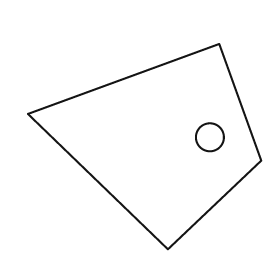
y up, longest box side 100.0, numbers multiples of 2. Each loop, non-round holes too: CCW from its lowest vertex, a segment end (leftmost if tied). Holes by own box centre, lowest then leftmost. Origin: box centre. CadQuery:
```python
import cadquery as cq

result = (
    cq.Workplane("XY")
    .moveTo(10.0, -44.0)
    .lineTo(50.0, -6.0)
    .lineTo(32.0, 44.0)
    .lineTo(-50.0, 14.0)
    .close()
    .moveTo(28.0, 4.0)
    .circle(6.0)
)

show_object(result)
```